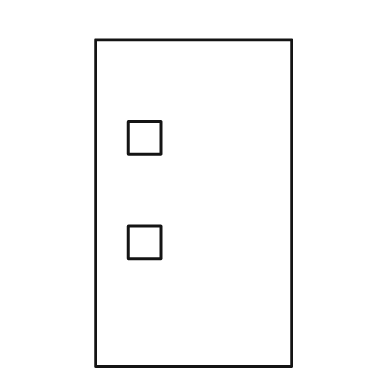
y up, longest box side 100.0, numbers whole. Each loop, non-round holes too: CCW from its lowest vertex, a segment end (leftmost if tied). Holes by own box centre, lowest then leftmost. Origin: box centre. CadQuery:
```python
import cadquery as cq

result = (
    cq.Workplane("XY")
    .moveTo(-30.0, -50.0)
    .lineTo(30.0, -50.0)
    .lineTo(30.0, 50.0)
    .lineTo(-30.0, 50.0)
    .close()
    .moveTo(-20.0, -17.0)
    .lineTo(-10.0, -17.0)
    .lineTo(-10.0, -7.0)
    .lineTo(-20.0, -7.0)
    .close()
    .moveTo(-20.0, 15.0)
    .lineTo(-10.0, 15.0)
    .lineTo(-10.0, 25.0)
    .lineTo(-20.0, 25.0)
    .close()
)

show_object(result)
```